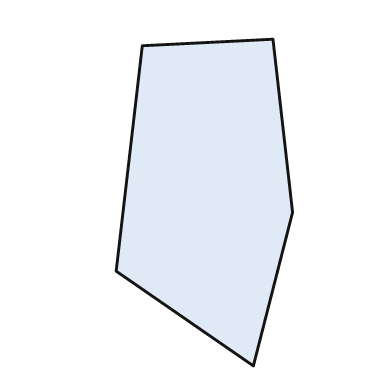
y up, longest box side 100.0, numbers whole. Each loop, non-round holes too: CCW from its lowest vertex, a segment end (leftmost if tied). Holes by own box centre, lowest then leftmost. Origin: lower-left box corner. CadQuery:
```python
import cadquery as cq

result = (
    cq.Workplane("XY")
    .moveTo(42.0, 0.0)
    .lineTo(54.0, 47.0)
    .lineTo(48.0, 100.0)
    .lineTo(8.0, 98.0)
    .lineTo(0.0, 29.0)
    .close()
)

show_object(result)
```